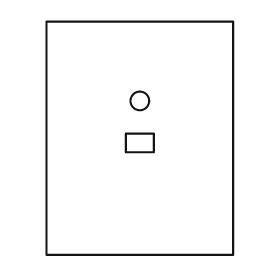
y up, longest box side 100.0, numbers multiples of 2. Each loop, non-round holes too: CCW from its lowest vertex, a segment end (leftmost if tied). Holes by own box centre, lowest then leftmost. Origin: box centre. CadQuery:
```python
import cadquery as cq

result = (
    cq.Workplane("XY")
    .moveTo(-40.0, -50.0)
    .lineTo(40.0, -50.0)
    .lineTo(40.0, 50.0)
    .lineTo(-40.0, 50.0)
    .close()
    .moveTo(-6.0, -6.0)
    .lineTo(6.0, -6.0)
    .lineTo(6.0, 2.0)
    .lineTo(-6.0, 2.0)
    .close()
    .moveTo(0.0, 16.0)
    .circle(4.0)
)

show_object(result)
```